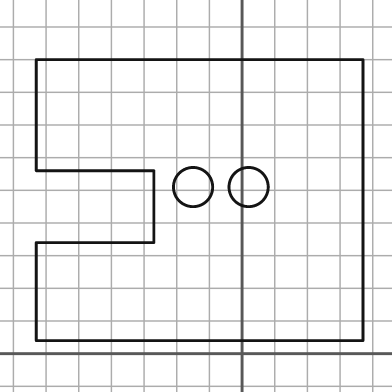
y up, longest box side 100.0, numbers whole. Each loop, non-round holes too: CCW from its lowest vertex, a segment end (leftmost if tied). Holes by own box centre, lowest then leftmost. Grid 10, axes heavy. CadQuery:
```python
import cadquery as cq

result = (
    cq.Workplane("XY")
    .moveTo(-63.0, 4.0)
    .lineTo(37.0, 4.0)
    .lineTo(37.0, 90.0)
    .lineTo(-63.0, 90.0)
    .lineTo(-63.0, 56.0)
    .lineTo(-27.0, 56.0)
    .lineTo(-27.0, 34.0)
    .lineTo(-63.0, 34.0)
    .close()
    .moveTo(-15.0, 51.0)
    .circle(6.0)
    .moveTo(2.0, 51.0)
    .circle(6.0)
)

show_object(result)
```